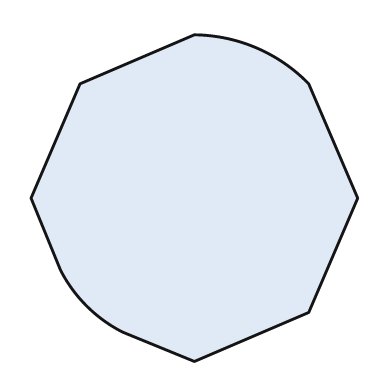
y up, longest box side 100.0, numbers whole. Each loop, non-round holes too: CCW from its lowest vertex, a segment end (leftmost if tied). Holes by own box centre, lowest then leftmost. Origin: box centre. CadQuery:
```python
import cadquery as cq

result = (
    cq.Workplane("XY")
    .moveTo(0.0, -50.0)
    .lineTo(35.0, -35.0)
    .lineTo(50.0, 0.0)
    .lineTo(35.0, 35.0)
    .threePointArc((19.0, 46.0), (0.0, 50.0))
    .lineTo(-35.0, 35.0)
    .lineTo(-50.0, 0.0)
    .lineTo(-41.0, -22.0)
    .threePointArc((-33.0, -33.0), (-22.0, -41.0))
    .close()
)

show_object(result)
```